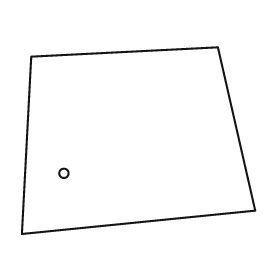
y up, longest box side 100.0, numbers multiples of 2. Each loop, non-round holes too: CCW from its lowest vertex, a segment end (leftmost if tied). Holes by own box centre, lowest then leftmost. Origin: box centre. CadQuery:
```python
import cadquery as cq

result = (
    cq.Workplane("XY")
    .moveTo(-50.0, -40.0)
    .lineTo(50.0, -30.0)
    .lineTo(34.0, 40.0)
    .lineTo(-46.0, 36.0)
    .close()
    .moveTo(-32.0, -14.0)
    .circle(2.0)
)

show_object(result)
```